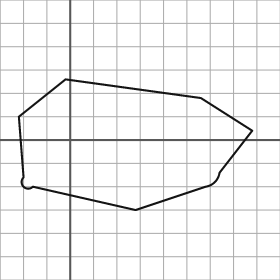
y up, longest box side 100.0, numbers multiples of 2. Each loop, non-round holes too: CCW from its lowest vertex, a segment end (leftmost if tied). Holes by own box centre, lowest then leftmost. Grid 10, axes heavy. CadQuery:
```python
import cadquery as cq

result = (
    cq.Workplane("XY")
    .moveTo(28.0, -30.0)
    .lineTo(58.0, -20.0)
    .threePointArc((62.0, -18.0), (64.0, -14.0))
    .lineTo(78.0, 4.0)
    .lineTo(56.0, 18.0)
    .lineTo(-2.0, 26.0)
    .lineTo(-22.0, 10.0)
    .lineTo(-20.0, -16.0)
    .threePointArc((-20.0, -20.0), (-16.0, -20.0))
    .close()
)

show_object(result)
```